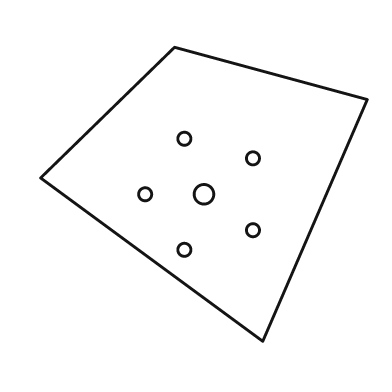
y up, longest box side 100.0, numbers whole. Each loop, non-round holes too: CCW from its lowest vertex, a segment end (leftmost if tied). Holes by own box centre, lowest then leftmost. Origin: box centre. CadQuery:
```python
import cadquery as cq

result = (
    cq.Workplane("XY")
    .moveTo(18.0, -45.0)
    .lineTo(50.0, 29.0)
    .lineTo(-9.0, 45.0)
    .lineTo(-50.0, 5.0)
    .close()
    .moveTo(-6.0, -17.0)
    .circle(2.0)
    .moveTo(15.0, -11.0)
    .circle(2.0)
    .moveTo(-18.0, 0.0)
    .circle(2.0)
    .moveTo(0.0, 0.0)
    .circle(3.0)
    .moveTo(15.0, 11.0)
    .circle(2.0)
    .moveTo(-6.0, 17.0)
    .circle(2.0)
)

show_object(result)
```